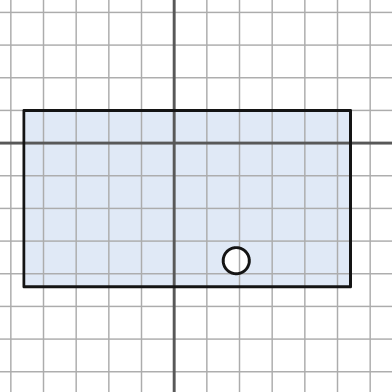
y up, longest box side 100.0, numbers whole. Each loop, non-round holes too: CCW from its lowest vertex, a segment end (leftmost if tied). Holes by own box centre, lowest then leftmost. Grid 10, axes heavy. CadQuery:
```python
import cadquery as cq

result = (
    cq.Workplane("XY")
    .moveTo(-46.0, -44.0)
    .lineTo(54.0, -44.0)
    .lineTo(54.0, 10.0)
    .lineTo(-46.0, 10.0)
    .close()
    .moveTo(19.0, -36.0)
    .circle(4.0)
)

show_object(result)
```